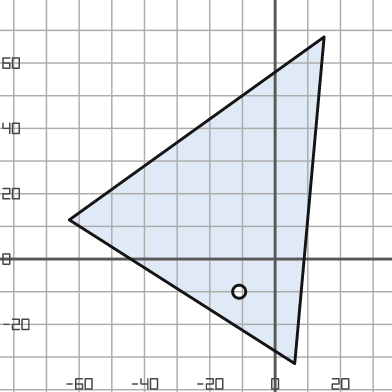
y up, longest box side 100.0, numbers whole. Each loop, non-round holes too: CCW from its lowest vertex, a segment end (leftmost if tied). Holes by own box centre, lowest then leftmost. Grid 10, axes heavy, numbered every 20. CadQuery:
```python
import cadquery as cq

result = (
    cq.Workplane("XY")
    .moveTo(6.0, -32.0)
    .lineTo(15.0, 68.0)
    .lineTo(-63.0, 12.0)
    .close()
    .moveTo(-11.0, -10.0)
    .circle(2.0)
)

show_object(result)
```